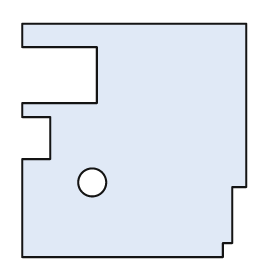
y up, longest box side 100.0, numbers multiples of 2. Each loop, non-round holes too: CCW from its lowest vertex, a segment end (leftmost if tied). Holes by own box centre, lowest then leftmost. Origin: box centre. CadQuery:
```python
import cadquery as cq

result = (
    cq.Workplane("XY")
    .moveTo(-48.0, -50.0)
    .lineTo(38.0, -50.0)
    .lineTo(38.0, -44.0)
    .lineTo(42.0, -44.0)
    .lineTo(42.0, -20.0)
    .lineTo(48.0, -20.0)
    .lineTo(48.0, 50.0)
    .lineTo(-48.0, 50.0)
    .lineTo(-48.0, 40.0)
    .lineTo(-16.0, 40.0)
    .lineTo(-16.0, 16.0)
    .lineTo(-48.0, 16.0)
    .lineTo(-48.0, 10.0)
    .lineTo(-36.0, 10.0)
    .lineTo(-36.0, -8.0)
    .lineTo(-48.0, -8.0)
    .close()
    .moveTo(-18.0, -18.0)
    .circle(6.0)
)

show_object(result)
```